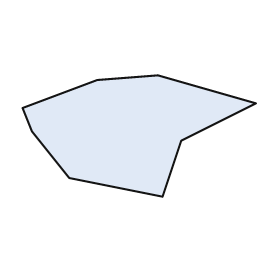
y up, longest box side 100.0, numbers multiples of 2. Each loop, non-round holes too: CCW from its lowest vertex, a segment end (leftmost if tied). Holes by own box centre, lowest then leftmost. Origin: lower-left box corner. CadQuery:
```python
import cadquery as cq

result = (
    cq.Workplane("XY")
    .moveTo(60.0, 0.0)
    .lineTo(68.0, 24.0)
    .lineTo(100.0, 40.0)
    .lineTo(58.0, 52.0)
    .lineTo(32.0, 50.0)
    .lineTo(0.0, 38.0)
    .lineTo(4.0, 28.0)
    .lineTo(20.0, 8.0)
    .close()
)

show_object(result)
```